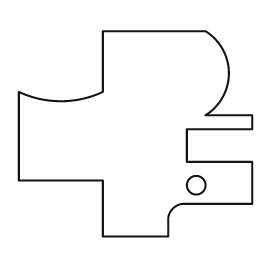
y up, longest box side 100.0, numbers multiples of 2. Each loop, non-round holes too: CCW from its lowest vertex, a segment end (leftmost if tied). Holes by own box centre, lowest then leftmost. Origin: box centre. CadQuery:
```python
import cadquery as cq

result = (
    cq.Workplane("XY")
    .moveTo(-14.0, -44.0)
    .lineTo(14.0, -44.0)
    .lineTo(14.0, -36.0)
    .threePointArc((16.0, -32.0), (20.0, -30.0))
    .lineTo(50.0, -30.0)
    .lineTo(50.0, -12.0)
    .lineTo(22.0, -12.0)
    .lineTo(22.0, 2.0)
    .lineTo(50.0, 2.0)
    .lineTo(50.0, 8.0)
    .lineTo(30.0, 8.0)
    .threePointArc((40.0, 26.0), (30.0, 44.0))
    .lineTo(-14.0, 44.0)
    .lineTo(-14.0, 18.0)
    .threePointArc((-32.0, 14.0), (-50.0, 18.0))
    .lineTo(-50.0, -20.0)
    .lineTo(-14.0, -20.0)
    .close()
    .moveTo(26.0, -22.0)
    .circle(4.0)
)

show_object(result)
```